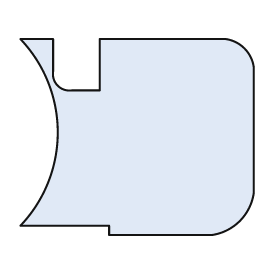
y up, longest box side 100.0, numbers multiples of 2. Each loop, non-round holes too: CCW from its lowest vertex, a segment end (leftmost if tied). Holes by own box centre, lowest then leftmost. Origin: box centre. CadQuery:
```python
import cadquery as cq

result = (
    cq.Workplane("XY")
    .moveTo(-12.0, -42.0)
    .lineTo(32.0, -42.0)
    .threePointArc((44.0, -36.0), (50.0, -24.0))
    .lineTo(50.0, 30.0)
    .threePointArc((46.0, 38.0), (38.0, 42.0))
    .lineTo(-16.0, 42.0)
    .lineTo(-16.0, 20.0)
    .lineTo(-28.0, 20.0)
    .threePointArc((-34.0, 22.0), (-36.0, 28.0))
    .lineTo(-36.0, 42.0)
    .lineTo(-50.0, 42.0)
    .threePointArc((-34.0, 2.0), (-50.0, -38.0))
    .lineTo(-12.0, -38.0)
    .close()
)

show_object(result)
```